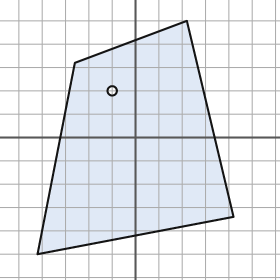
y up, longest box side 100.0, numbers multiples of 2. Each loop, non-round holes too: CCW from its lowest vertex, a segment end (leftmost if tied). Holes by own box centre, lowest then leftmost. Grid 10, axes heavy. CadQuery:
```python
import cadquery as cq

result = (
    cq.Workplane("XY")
    .moveTo(-42.0, -50.0)
    .lineTo(42.0, -34.0)
    .lineTo(22.0, 50.0)
    .lineTo(-26.0, 32.0)
    .close()
    .moveTo(-10.0, 20.0)
    .circle(2.0)
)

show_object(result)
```